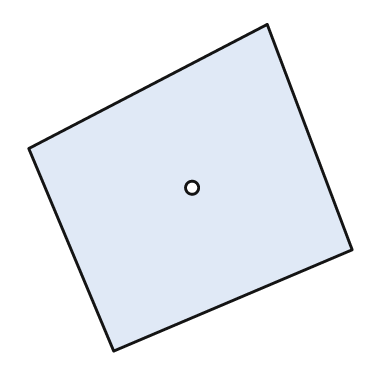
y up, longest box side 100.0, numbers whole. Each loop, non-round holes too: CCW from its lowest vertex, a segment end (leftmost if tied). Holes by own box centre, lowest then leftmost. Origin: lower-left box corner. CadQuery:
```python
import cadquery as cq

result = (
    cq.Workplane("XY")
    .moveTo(26.0, 0.0)
    .lineTo(99.0, 31.0)
    .lineTo(73.0, 100.0)
    .lineTo(0.0, 62.0)
    .close()
    .moveTo(50.0, 50.0)
    .circle(2.0)
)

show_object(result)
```